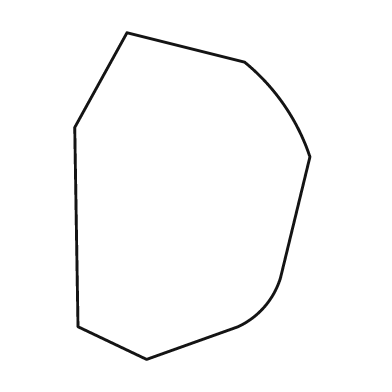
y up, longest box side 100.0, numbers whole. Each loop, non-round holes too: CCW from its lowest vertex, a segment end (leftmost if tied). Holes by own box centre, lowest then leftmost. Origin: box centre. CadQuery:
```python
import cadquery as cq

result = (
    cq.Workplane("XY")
    .moveTo(-14.0, -50.0)
    .lineTo(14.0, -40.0)
    .threePointArc((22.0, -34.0), (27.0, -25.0))
    .lineTo(36.0, 12.0)
    .threePointArc((28.0, 28.0), (16.0, 41.0))
    .lineTo(-20.0, 50.0)
    .lineTo(-36.0, 21.0)
    .lineTo(-35.0, -40.0)
    .close()
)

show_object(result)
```